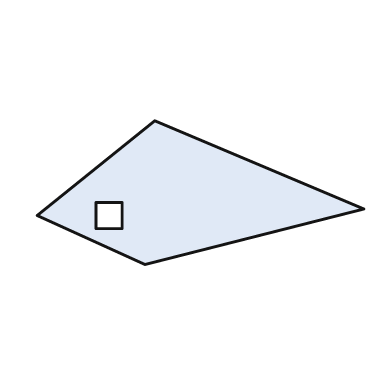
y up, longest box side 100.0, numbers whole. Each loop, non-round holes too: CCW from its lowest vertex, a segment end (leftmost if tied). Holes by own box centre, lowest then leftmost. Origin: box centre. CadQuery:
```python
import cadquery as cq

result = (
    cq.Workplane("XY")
    .moveTo(-17.0, -22.0)
    .lineTo(50.0, -5.0)
    .lineTo(-14.0, 22.0)
    .lineTo(-50.0, -7.0)
    .close()
    .moveTo(-32.0, -11.0)
    .lineTo(-24.0, -11.0)
    .lineTo(-24.0, -3.0)
    .lineTo(-32.0, -3.0)
    .close()
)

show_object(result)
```